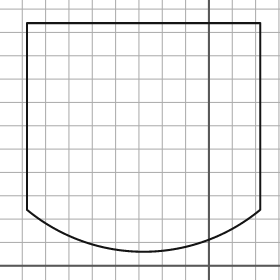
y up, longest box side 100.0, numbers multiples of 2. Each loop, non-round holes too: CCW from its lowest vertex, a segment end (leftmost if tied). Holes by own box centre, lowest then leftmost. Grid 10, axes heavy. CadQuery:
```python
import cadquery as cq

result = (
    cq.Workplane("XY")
    .moveTo(-78.0, 24.0)
    .threePointArc((-28.0, 6.0), (22.0, 24.0))
    .lineTo(22.0, 104.0)
    .lineTo(-78.0, 104.0)
    .close()
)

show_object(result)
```